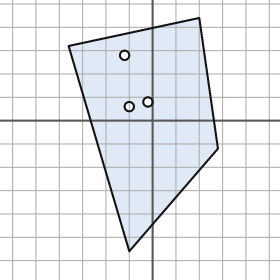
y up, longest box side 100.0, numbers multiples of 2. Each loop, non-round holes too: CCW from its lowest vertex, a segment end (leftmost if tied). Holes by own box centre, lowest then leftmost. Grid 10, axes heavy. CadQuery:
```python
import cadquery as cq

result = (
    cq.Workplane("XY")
    .moveTo(-10.0, -56.0)
    .lineTo(28.0, -12.0)
    .lineTo(20.0, 44.0)
    .lineTo(-36.0, 32.0)
    .close()
    .moveTo(-10.0, 6.0)
    .circle(2.0)
    .moveTo(-2.0, 8.0)
    .circle(2.0)
    .moveTo(-12.0, 28.0)
    .circle(2.0)
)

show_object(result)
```